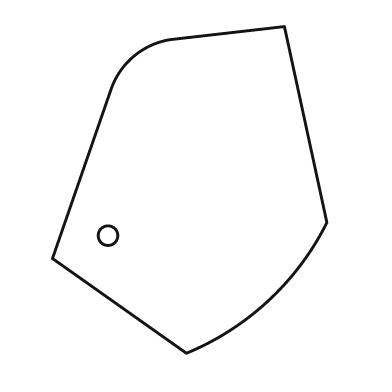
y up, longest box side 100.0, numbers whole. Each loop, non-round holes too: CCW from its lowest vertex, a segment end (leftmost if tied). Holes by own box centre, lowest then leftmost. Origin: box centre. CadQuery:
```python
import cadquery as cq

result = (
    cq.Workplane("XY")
    .moveTo(-1.0, -50.0)
    .threePointArc((24.0, -34.0), (42.0, -10.0))
    .lineTo(29.0, 50.0)
    .lineTo(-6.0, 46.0)
    .threePointArc((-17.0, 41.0), (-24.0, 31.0))
    .lineTo(-42.0, -21.0)
    .close()
    .moveTo(-25.0, -14.0)
    .circle(3.0)
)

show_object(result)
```